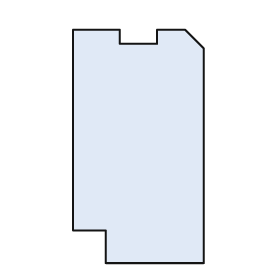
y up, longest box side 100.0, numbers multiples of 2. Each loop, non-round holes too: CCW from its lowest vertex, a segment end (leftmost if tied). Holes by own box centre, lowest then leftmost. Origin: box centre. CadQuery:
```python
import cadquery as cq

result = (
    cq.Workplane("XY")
    .moveTo(-14.0, -50.0)
    .lineTo(28.0, -50.0)
    .lineTo(28.0, 42.0)
    .lineTo(20.0, 50.0)
    .lineTo(8.0, 50.0)
    .lineTo(8.0, 44.0)
    .lineTo(-8.0, 44.0)
    .lineTo(-8.0, 50.0)
    .lineTo(-28.0, 50.0)
    .lineTo(-28.0, -36.0)
    .lineTo(-14.0, -36.0)
    .close()
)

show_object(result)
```